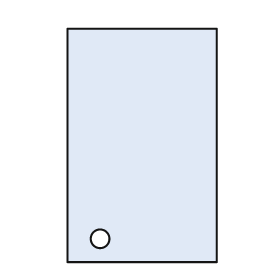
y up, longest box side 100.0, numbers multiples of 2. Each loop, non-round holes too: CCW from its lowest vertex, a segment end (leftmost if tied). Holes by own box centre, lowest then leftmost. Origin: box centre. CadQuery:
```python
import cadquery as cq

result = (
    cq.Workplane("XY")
    .moveTo(-32.0, -50.0)
    .lineTo(32.0, -50.0)
    .lineTo(32.0, 50.0)
    .lineTo(-32.0, 50.0)
    .close()
    .moveTo(-18.0, -40.0)
    .circle(4.0)
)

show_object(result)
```